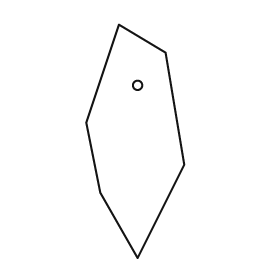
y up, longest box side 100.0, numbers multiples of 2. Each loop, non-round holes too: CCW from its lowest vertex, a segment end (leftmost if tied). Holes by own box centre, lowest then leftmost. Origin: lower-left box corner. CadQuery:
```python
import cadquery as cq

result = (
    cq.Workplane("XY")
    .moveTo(22.0, 0.0)
    .lineTo(42.0, 40.0)
    .lineTo(34.0, 88.0)
    .lineTo(14.0, 100.0)
    .lineTo(0.0, 58.0)
    .lineTo(6.0, 28.0)
    .close()
    .moveTo(22.0, 74.0)
    .circle(2.0)
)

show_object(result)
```